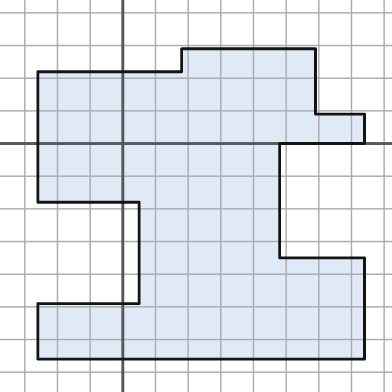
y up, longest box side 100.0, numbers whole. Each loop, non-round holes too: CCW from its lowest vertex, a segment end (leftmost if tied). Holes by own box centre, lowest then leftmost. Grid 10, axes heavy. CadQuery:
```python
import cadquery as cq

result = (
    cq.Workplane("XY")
    .moveTo(-26.0, -66.0)
    .lineTo(74.0, -66.0)
    .lineTo(74.0, -35.0)
    .lineTo(48.0, -35.0)
    .lineTo(48.0, 0.0)
    .lineTo(74.0, 0.0)
    .lineTo(74.0, 9.0)
    .lineTo(59.0, 9.0)
    .lineTo(59.0, 29.0)
    .lineTo(18.0, 29.0)
    .lineTo(18.0, 22.0)
    .lineTo(-26.0, 22.0)
    .lineTo(-26.0, -18.0)
    .lineTo(5.0, -18.0)
    .lineTo(5.0, -49.0)
    .lineTo(-26.0, -49.0)
    .close()
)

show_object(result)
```